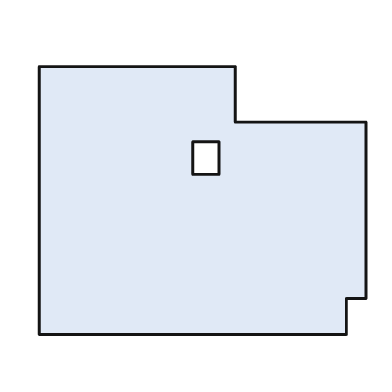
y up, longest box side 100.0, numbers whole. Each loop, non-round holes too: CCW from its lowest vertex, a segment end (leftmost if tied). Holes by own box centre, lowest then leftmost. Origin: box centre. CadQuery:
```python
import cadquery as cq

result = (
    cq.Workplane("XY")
    .moveTo(-50.0, -41.0)
    .lineTo(44.0, -41.0)
    .lineTo(44.0, -30.0)
    .lineTo(50.0, -30.0)
    .lineTo(50.0, 24.0)
    .lineTo(10.0, 24.0)
    .lineTo(10.0, 41.0)
    .lineTo(-50.0, 41.0)
    .close()
    .moveTo(-3.0, 8.0)
    .lineTo(5.0, 8.0)
    .lineTo(5.0, 18.0)
    .lineTo(-3.0, 18.0)
    .close()
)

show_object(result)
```